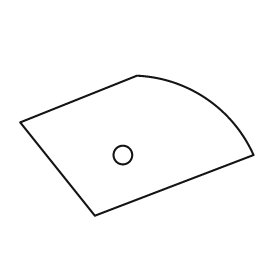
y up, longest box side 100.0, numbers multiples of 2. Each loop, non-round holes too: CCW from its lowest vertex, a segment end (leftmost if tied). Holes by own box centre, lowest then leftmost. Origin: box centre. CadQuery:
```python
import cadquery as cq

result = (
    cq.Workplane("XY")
    .moveTo(-18.0, -30.0)
    .lineTo(50.0, -4.0)
    .threePointArc((30.0, 20.0), (0.0, 30.0))
    .lineTo(-50.0, 10.0)
    .close()
    .moveTo(-6.0, -4.0)
    .circle(4.0)
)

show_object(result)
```